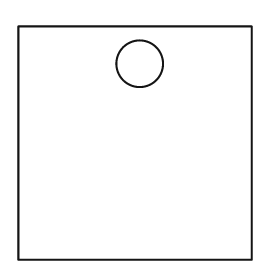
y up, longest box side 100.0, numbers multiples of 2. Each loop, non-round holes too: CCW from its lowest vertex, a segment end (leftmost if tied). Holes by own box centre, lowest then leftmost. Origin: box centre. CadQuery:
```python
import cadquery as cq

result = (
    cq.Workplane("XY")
    .moveTo(-50.0, -50.0)
    .lineTo(50.0, -50.0)
    .lineTo(50.0, 50.0)
    .lineTo(-50.0, 50.0)
    .close()
    .moveTo(2.0, 34.0)
    .circle(10.0)
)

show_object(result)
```